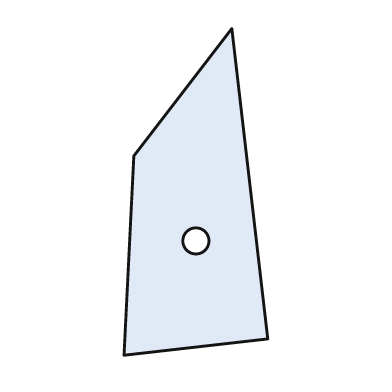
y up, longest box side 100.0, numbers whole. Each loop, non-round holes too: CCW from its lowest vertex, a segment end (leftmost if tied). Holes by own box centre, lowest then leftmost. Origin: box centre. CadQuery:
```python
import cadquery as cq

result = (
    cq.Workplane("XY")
    .moveTo(-22.0, -50.0)
    .lineTo(22.0, -45.0)
    .lineTo(11.0, 50.0)
    .lineTo(-19.0, 11.0)
    .close()
    .moveTo(0.0, -15.0)
    .circle(4.0)
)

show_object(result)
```